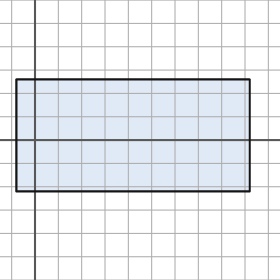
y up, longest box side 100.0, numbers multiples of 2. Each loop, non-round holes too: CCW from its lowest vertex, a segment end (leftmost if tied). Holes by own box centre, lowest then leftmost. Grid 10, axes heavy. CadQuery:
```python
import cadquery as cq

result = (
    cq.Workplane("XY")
    .moveTo(-8.0, -22.0)
    .lineTo(92.0, -22.0)
    .lineTo(92.0, 26.0)
    .lineTo(-8.0, 26.0)
    .close()
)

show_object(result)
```